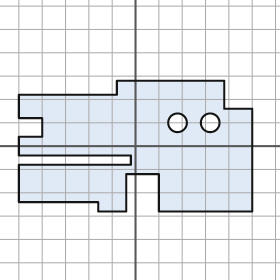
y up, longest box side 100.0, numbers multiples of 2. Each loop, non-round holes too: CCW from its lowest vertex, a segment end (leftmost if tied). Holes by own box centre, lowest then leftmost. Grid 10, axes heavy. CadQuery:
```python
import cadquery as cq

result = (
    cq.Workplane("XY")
    .moveTo(-16.0, -28.0)
    .lineTo(-4.0, -28.0)
    .lineTo(-4.0, -12.0)
    .lineTo(10.0, -12.0)
    .lineTo(10.0, -28.0)
    .lineTo(50.0, -28.0)
    .lineTo(50.0, 16.0)
    .lineTo(38.0, 16.0)
    .lineTo(38.0, 28.0)
    .lineTo(-8.0, 28.0)
    .lineTo(-8.0, 22.0)
    .lineTo(-50.0, 22.0)
    .lineTo(-50.0, 12.0)
    .lineTo(-40.0, 12.0)
    .lineTo(-40.0, 4.0)
    .lineTo(-50.0, 4.0)
    .lineTo(-50.0, -4.0)
    .lineTo(-2.0, -4.0)
    .lineTo(-2.0, -8.0)
    .lineTo(-50.0, -8.0)
    .lineTo(-50.0, -24.0)
    .lineTo(-16.0, -24.0)
    .close()
    .moveTo(18.0, 10.0)
    .circle(4.0)
    .moveTo(32.0, 10.0)
    .circle(4.0)
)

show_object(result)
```